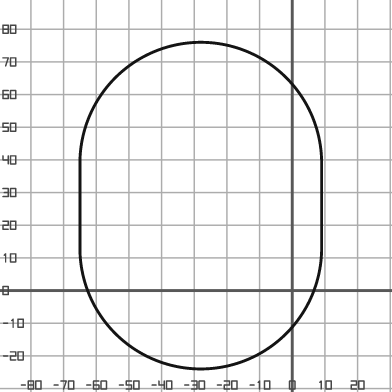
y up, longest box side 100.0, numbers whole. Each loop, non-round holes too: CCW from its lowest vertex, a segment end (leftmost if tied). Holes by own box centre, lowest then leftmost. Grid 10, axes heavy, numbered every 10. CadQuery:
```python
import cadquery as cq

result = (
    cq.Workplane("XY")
    .moveTo(-65.0, 13.0)
    .threePointArc((-28.0, -24.0), (9.0, 13.0))
    .lineTo(9.0, 39.0)
    .threePointArc((-28.0, 76.0), (-65.0, 39.0))
    .close()
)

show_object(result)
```